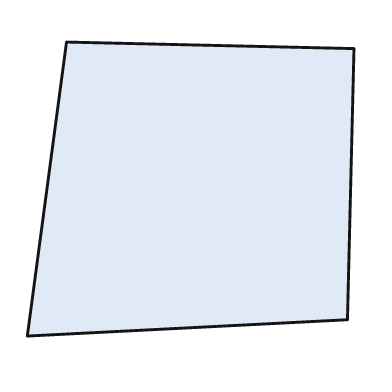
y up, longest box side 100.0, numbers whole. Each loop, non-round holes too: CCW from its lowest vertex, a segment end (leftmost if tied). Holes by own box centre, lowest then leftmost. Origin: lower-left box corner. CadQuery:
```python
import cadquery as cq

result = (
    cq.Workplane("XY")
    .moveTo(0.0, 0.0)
    .lineTo(98.0, 5.0)
    .lineTo(100.0, 88.0)
    .lineTo(12.0, 90.0)
    .close()
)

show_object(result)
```